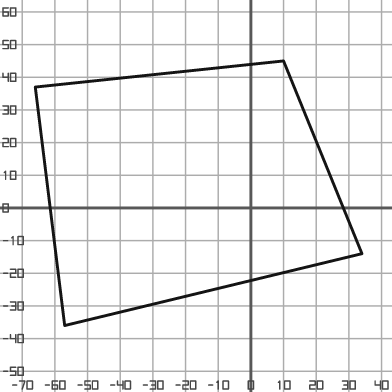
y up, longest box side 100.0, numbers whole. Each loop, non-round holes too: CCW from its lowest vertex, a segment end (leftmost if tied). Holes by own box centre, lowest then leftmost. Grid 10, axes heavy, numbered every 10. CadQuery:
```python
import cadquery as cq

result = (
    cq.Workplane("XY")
    .moveTo(-57.0, -36.0)
    .lineTo(34.0, -14.0)
    .lineTo(10.0, 45.0)
    .lineTo(-66.0, 37.0)
    .close()
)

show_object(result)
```